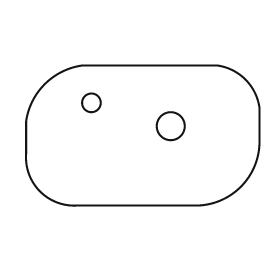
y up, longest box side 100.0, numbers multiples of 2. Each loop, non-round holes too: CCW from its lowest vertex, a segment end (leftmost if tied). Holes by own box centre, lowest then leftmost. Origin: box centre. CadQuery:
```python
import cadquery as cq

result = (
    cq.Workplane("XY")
    .moveTo(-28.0, -30.0)
    .lineTo(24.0, -30.0)
    .threePointArc((42.0, -22.0), (50.0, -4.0))
    .lineTo(50.0, 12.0)
    .threePointArc((44.0, 24.0), (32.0, 30.0))
    .lineTo(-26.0, 30.0)
    .threePointArc((-42.0, 22.0), (-50.0, 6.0))
    .lineTo(-50.0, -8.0)
    .threePointArc((-44.0, -24.0), (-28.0, -30.0))
    .close()
    .moveTo(12.0, 4.0)
    .circle(6.0)
    .moveTo(-22.0, 14.0)
    .circle(4.0)
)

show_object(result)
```